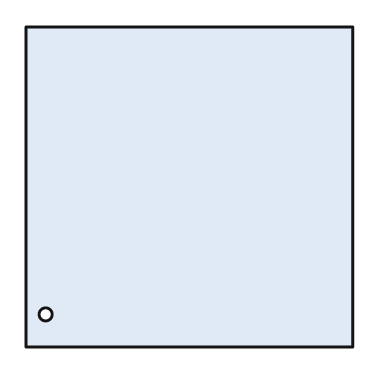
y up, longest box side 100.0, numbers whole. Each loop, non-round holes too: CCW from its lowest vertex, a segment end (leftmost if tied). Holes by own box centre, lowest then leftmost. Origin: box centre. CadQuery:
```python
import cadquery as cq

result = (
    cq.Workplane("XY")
    .moveTo(-50.0, -49.0)
    .lineTo(50.0, -49.0)
    .lineTo(50.0, 49.0)
    .lineTo(-50.0, 49.0)
    .close()
    .moveTo(-44.0, -39.0)
    .circle(2.0)
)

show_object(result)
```